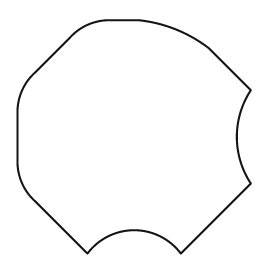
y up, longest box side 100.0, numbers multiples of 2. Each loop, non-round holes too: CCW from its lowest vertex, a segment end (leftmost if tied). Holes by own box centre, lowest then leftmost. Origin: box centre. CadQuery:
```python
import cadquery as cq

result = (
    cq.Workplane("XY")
    .moveTo(-20.0, -50.0)
    .threePointArc((0.0, -40.0), (20.0, -50.0))
    .lineTo(50.0, -20.0)
    .threePointArc((44.0, 0.0), (50.0, 20.0))
    .lineTo(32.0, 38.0)
    .threePointArc((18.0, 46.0), (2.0, 50.0))
    .lineTo(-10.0, 50.0)
    .threePointArc((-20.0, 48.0), (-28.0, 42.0))
    .lineTo(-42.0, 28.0)
    .threePointArc((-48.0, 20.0), (-50.0, 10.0))
    .lineTo(-50.0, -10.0)
    .threePointArc((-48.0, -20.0), (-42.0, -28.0))
    .close()
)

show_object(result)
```